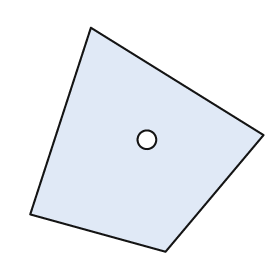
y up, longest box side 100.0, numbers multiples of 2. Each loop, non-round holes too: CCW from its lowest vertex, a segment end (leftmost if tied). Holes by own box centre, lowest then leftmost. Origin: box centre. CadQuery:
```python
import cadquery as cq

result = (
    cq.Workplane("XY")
    .moveTo(8.0, -48.0)
    .lineTo(50.0, 2.0)
    .lineTo(-24.0, 48.0)
    .lineTo(-50.0, -32.0)
    .close()
    .moveTo(0.0, 0.0)
    .circle(4.0)
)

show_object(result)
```